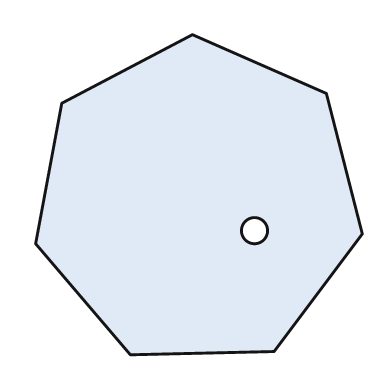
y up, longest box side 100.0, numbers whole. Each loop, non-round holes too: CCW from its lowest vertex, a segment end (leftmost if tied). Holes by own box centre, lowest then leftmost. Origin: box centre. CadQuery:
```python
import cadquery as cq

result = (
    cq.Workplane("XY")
    .moveTo(-21.0, -49.0)
    .lineTo(23.0, -48.0)
    .lineTo(50.0, -12.0)
    .lineTo(39.0, 31.0)
    .lineTo(-2.0, 49.0)
    .lineTo(-42.0, 28.0)
    .lineTo(-50.0, -15.0)
    .close()
    .moveTo(17.0, -11.0)
    .circle(4.0)
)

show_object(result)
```